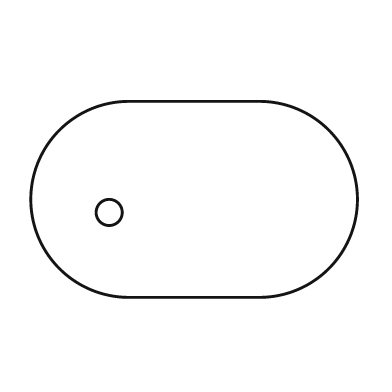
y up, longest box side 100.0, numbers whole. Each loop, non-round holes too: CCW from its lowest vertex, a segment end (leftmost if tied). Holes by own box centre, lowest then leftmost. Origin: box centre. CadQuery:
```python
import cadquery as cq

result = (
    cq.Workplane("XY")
    .moveTo(-20.0, -30.0)
    .lineTo(20.0, -30.0)
    .threePointArc((50.0, 0.0), (20.0, 30.0))
    .lineTo(-20.0, 30.0)
    .threePointArc((-50.0, 0.0), (-20.0, -30.0))
    .close()
    .moveTo(-26.0, -4.0)
    .circle(4.0)
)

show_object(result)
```